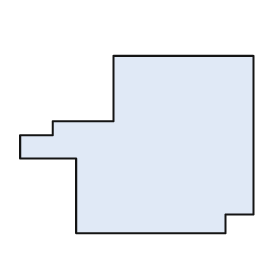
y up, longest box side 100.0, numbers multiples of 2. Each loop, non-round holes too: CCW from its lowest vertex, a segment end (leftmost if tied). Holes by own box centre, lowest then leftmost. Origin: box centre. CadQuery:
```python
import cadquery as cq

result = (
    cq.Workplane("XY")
    .moveTo(-26.0, -38.0)
    .lineTo(38.0, -38.0)
    .lineTo(38.0, -30.0)
    .lineTo(50.0, -30.0)
    .lineTo(50.0, 38.0)
    .lineTo(-10.0, 38.0)
    .lineTo(-10.0, 10.0)
    .lineTo(-36.0, 10.0)
    .lineTo(-36.0, 4.0)
    .lineTo(-50.0, 4.0)
    .lineTo(-50.0, -6.0)
    .lineTo(-26.0, -6.0)
    .close()
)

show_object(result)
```